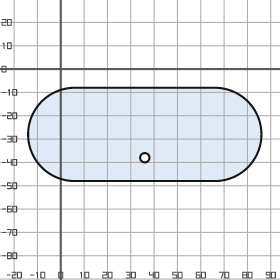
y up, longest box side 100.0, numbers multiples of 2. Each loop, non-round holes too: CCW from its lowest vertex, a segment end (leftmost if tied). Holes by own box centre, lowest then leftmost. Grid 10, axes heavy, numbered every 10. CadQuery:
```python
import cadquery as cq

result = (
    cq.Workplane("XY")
    .moveTo(6.0, -48.0)
    .lineTo(66.0, -48.0)
    .threePointArc((86.0, -28.0), (66.0, -8.0))
    .lineTo(6.0, -8.0)
    .threePointArc((-14.0, -28.0), (6.0, -48.0))
    .close()
    .moveTo(36.0, -38.0)
    .circle(2.0)
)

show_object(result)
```